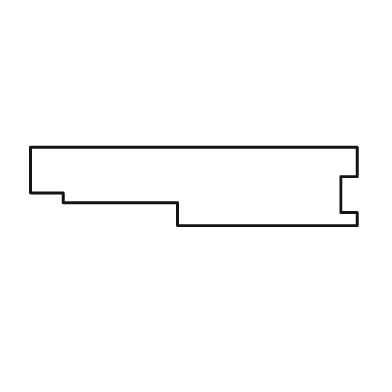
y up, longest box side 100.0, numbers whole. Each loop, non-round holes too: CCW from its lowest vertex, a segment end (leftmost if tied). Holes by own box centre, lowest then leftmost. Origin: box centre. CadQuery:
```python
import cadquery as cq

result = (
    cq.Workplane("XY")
    .moveTo(-5.0, -12.0)
    .lineTo(50.0, -12.0)
    .lineTo(50.0, -8.0)
    .lineTo(45.0, -8.0)
    .lineTo(45.0, 3.0)
    .lineTo(50.0, 3.0)
    .lineTo(50.0, 12.0)
    .lineTo(-50.0, 12.0)
    .lineTo(-50.0, -2.0)
    .lineTo(-40.0, -2.0)
    .lineTo(-40.0, -5.0)
    .lineTo(-5.0, -5.0)
    .close()
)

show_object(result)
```